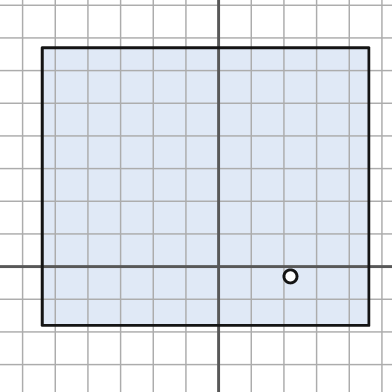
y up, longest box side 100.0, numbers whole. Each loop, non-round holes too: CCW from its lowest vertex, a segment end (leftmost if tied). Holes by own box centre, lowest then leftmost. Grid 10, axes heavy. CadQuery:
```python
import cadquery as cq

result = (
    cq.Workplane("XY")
    .moveTo(-54.0, -18.0)
    .lineTo(46.0, -18.0)
    .lineTo(46.0, 67.0)
    .lineTo(-54.0, 67.0)
    .close()
    .moveTo(22.0, -3.0)
    .circle(2.0)
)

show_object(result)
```